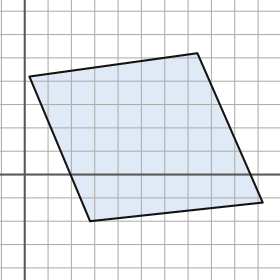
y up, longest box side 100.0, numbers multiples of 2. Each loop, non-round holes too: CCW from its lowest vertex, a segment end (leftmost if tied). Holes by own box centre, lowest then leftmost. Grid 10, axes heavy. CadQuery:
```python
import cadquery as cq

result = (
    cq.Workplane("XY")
    .moveTo(28.0, -20.0)
    .lineTo(102.0, -12.0)
    .lineTo(74.0, 52.0)
    .lineTo(2.0, 42.0)
    .close()
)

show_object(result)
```